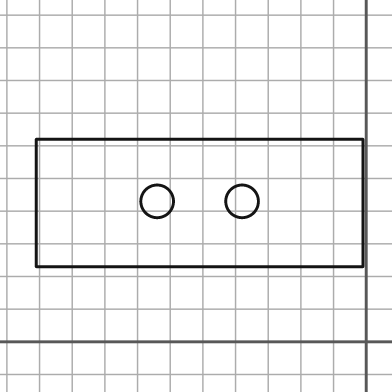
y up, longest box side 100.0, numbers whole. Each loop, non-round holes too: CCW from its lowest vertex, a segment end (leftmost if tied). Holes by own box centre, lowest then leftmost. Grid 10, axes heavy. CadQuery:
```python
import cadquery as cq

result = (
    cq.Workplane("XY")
    .moveTo(-101.0, 23.0)
    .lineTo(-1.0, 23.0)
    .lineTo(-1.0, 62.0)
    .lineTo(-101.0, 62.0)
    .close()
    .moveTo(-64.0, 43.0)
    .circle(5.0)
    .moveTo(-38.0, 43.0)
    .circle(5.0)
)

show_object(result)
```